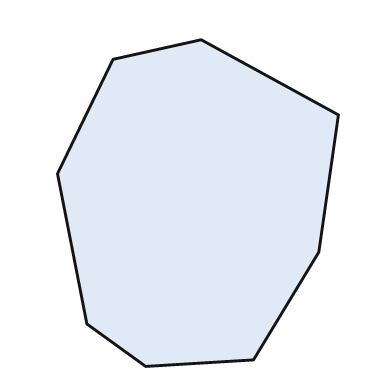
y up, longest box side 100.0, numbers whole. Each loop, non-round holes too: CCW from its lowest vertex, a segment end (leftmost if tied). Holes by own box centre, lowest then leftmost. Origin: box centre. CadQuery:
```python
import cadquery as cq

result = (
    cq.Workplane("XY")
    .moveTo(-16.0, -50.0)
    .lineTo(17.0, -48.0)
    .lineTo(37.0, -15.0)
    .lineTo(43.0, 27.0)
    .lineTo(1.0, 50.0)
    .lineTo(-26.0, 44.0)
    .lineTo(-43.0, 9.0)
    .lineTo(-34.0, -37.0)
    .close()
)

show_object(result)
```